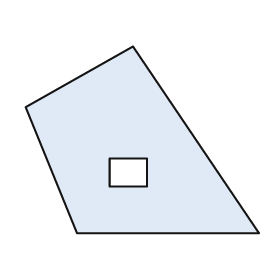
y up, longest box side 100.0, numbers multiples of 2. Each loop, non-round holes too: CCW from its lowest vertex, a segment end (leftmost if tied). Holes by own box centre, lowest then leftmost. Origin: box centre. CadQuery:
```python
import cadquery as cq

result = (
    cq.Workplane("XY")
    .moveTo(-28.0, -40.0)
    .lineTo(50.0, -40.0)
    .lineTo(-4.0, 40.0)
    .lineTo(-50.0, 14.0)
    .close()
    .moveTo(-14.0, -20.0)
    .lineTo(2.0, -20.0)
    .lineTo(2.0, -8.0)
    .lineTo(-14.0, -8.0)
    .close()
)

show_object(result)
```